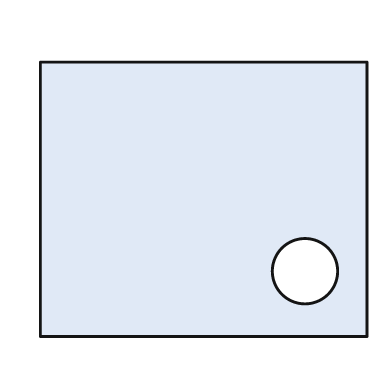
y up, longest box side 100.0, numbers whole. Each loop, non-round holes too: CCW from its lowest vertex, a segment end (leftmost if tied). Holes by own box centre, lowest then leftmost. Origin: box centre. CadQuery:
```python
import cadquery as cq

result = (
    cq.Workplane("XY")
    .moveTo(-50.0, -42.0)
    .lineTo(50.0, -42.0)
    .lineTo(50.0, 42.0)
    .lineTo(-50.0, 42.0)
    .close()
    .moveTo(31.0, -22.0)
    .circle(10.0)
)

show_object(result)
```